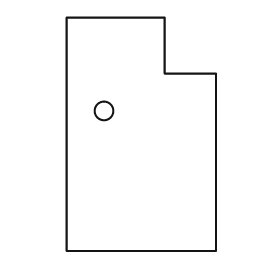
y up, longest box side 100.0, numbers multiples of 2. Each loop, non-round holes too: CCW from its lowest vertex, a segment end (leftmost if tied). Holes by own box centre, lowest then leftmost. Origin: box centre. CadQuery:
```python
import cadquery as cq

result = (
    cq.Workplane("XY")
    .moveTo(-32.0, -50.0)
    .lineTo(32.0, -50.0)
    .lineTo(32.0, 26.0)
    .lineTo(10.0, 26.0)
    .lineTo(10.0, 50.0)
    .lineTo(-32.0, 50.0)
    .close()
    .moveTo(-16.0, 10.0)
    .circle(4.0)
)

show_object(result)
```